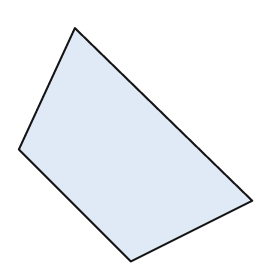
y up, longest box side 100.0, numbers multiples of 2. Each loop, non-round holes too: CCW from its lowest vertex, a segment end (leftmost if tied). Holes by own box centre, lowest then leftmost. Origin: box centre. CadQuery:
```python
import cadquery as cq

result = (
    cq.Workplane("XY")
    .moveTo(-2.0, -50.0)
    .lineTo(50.0, -24.0)
    .lineTo(-26.0, 50.0)
    .lineTo(-50.0, -2.0)
    .close()
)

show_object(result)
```